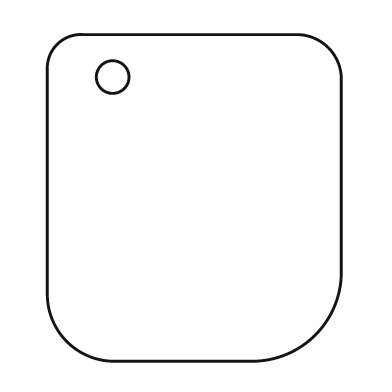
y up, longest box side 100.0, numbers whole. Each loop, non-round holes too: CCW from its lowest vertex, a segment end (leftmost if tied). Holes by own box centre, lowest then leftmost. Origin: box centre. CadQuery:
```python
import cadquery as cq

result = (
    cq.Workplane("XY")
    .moveTo(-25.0, -50.0)
    .lineTo(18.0, -50.0)
    .threePointArc((37.0, -42.0), (45.0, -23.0))
    .lineTo(45.0, 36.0)
    .threePointArc((41.0, 46.0), (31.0, 50.0))
    .lineTo(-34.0, 50.0)
    .threePointArc((-42.0, 47.0), (-45.0, 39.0))
    .lineTo(-45.0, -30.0)
    .threePointArc((-39.0, -44.0), (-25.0, -50.0))
    .close()
    .moveTo(-25.0, 37.0)
    .circle(5.0)
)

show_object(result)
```